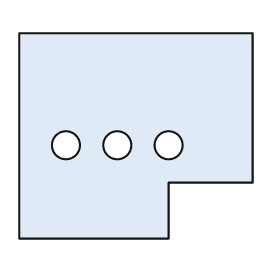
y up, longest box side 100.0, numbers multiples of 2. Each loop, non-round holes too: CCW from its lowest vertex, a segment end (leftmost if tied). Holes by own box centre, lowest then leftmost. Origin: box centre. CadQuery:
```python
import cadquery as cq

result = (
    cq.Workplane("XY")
    .moveTo(-50.0, -44.0)
    .lineTo(14.0, -44.0)
    .lineTo(14.0, -20.0)
    .lineTo(50.0, -20.0)
    .lineTo(50.0, 44.0)
    .lineTo(-50.0, 44.0)
    .close()
    .moveTo(-30.0, -4.0)
    .circle(6.0)
    .moveTo(-8.0, -4.0)
    .circle(6.0)
    .moveTo(14.0, -4.0)
    .circle(6.0)
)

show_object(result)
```